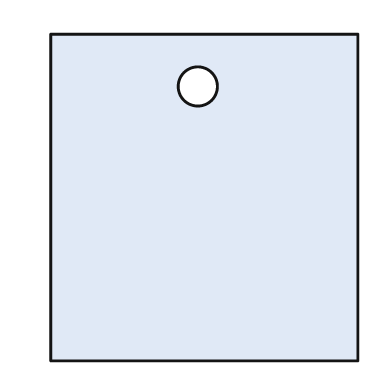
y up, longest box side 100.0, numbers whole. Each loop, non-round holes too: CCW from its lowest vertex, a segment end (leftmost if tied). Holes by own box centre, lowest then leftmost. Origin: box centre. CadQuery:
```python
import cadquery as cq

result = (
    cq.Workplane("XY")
    .moveTo(-47.0, -50.0)
    .lineTo(47.0, -50.0)
    .lineTo(47.0, 50.0)
    .lineTo(-47.0, 50.0)
    .close()
    .moveTo(-2.0, 34.0)
    .circle(6.0)
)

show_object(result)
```